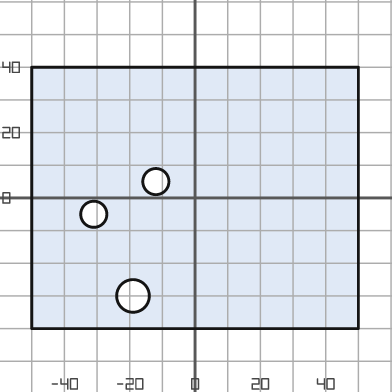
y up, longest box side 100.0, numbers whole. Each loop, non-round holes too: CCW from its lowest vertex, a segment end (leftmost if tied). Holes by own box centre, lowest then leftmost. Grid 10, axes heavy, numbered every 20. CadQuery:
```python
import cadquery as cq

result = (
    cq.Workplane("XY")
    .moveTo(-50.0, -40.0)
    .lineTo(50.0, -40.0)
    .lineTo(50.0, 40.0)
    .lineTo(-50.0, 40.0)
    .close()
    .moveTo(-19.0, -30.0)
    .circle(5.0)
    .moveTo(-31.0, -5.0)
    .circle(4.0)
    .moveTo(-12.0, 5.0)
    .circle(4.0)
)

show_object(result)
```